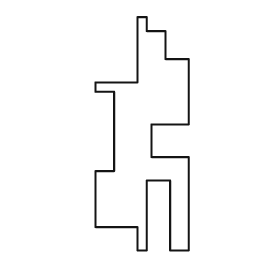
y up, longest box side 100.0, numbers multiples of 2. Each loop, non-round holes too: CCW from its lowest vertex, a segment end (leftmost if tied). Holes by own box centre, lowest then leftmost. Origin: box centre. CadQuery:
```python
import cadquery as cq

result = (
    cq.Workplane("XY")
    .moveTo(-2.0, -50.0)
    .lineTo(2.0, -50.0)
    .lineTo(2.0, -20.0)
    .lineTo(12.0, -20.0)
    .lineTo(12.0, -50.0)
    .lineTo(20.0, -50.0)
    .lineTo(20.0, -10.0)
    .lineTo(4.0, -10.0)
    .lineTo(4.0, 4.0)
    .lineTo(20.0, 4.0)
    .lineTo(20.0, 32.0)
    .lineTo(10.0, 32.0)
    .lineTo(10.0, 44.0)
    .lineTo(2.0, 44.0)
    .lineTo(2.0, 50.0)
    .lineTo(-2.0, 50.0)
    .lineTo(-2.0, 22.0)
    .lineTo(-20.0, 22.0)
    .lineTo(-20.0, 18.0)
    .lineTo(-12.0, 18.0)
    .lineTo(-12.0, -16.0)
    .lineTo(-20.0, -16.0)
    .lineTo(-20.0, -40.0)
    .lineTo(-2.0, -40.0)
    .close()
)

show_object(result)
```